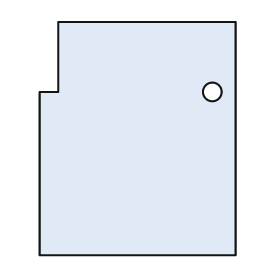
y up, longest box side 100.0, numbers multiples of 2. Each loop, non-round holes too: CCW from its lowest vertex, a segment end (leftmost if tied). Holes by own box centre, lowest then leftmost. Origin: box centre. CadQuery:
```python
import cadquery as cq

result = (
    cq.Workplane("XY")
    .moveTo(-42.0, -50.0)
    .lineTo(42.0, -50.0)
    .lineTo(42.0, 50.0)
    .lineTo(-34.0, 50.0)
    .lineTo(-34.0, 20.0)
    .lineTo(-42.0, 20.0)
    .close()
    .moveTo(32.0, 20.0)
    .circle(4.0)
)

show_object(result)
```